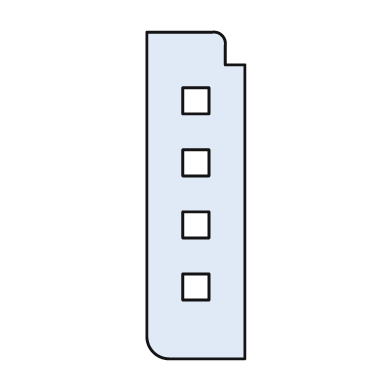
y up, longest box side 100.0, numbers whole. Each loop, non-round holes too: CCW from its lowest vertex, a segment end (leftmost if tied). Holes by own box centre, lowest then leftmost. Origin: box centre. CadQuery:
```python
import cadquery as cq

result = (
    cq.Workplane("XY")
    .moveTo(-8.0, -50.0)
    .lineTo(15.0, -50.0)
    .lineTo(15.0, 40.0)
    .lineTo(9.0, 40.0)
    .lineTo(9.0, 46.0)
    .threePointArc((8.0, 49.0), (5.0, 50.0))
    .lineTo(-15.0, 50.0)
    .lineTo(-15.0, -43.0)
    .threePointArc((-13.0, -48.0), (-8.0, -50.0))
    .close()
    .moveTo(-4.0, -32.0)
    .lineTo(4.0, -32.0)
    .lineTo(4.0, -24.0)
    .lineTo(-4.0, -24.0)
    .close()
    .moveTo(-4.0, -13.0)
    .lineTo(4.0, -13.0)
    .lineTo(4.0, -5.0)
    .lineTo(-4.0, -5.0)
    .close()
    .moveTo(-4.0, 6.0)
    .lineTo(4.0, 6.0)
    .lineTo(4.0, 14.0)
    .lineTo(-4.0, 14.0)
    .close()
    .moveTo(-4.0, 25.0)
    .lineTo(4.0, 25.0)
    .lineTo(4.0, 33.0)
    .lineTo(-4.0, 33.0)
    .close()
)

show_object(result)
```